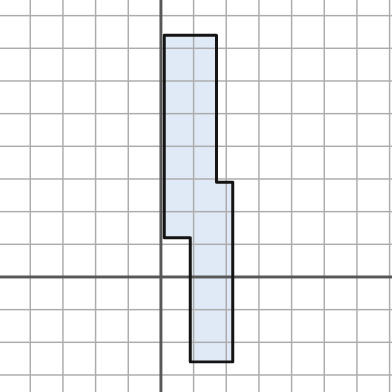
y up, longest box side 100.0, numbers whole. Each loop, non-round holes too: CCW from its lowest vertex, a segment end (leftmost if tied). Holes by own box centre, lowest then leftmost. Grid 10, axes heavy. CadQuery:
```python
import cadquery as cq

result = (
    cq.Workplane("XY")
    .moveTo(9.0, -26.0)
    .lineTo(22.0, -26.0)
    .lineTo(22.0, 29.0)
    .lineTo(17.0, 29.0)
    .lineTo(17.0, 74.0)
    .lineTo(1.0, 74.0)
    .lineTo(1.0, 12.0)
    .lineTo(9.0, 12.0)
    .close()
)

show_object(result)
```